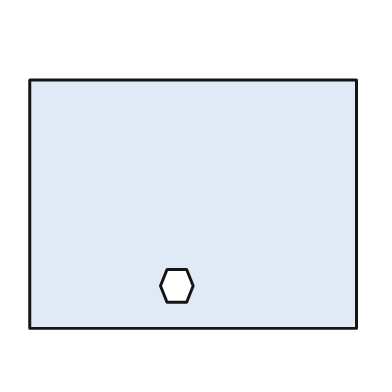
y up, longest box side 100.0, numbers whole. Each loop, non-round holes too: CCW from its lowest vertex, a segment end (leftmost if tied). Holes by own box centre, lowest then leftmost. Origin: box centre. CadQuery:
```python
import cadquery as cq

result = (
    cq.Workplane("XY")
    .moveTo(-50.0, -38.0)
    .lineTo(50.0, -38.0)
    .lineTo(50.0, 38.0)
    .lineTo(-50.0, 38.0)
    .close()
    .moveTo(-8.0, -30.0)
    .lineTo(-2.0, -30.0)
    .lineTo(0.0, -25.0)
    .lineTo(-2.0, -20.0)
    .lineTo(-8.0, -20.0)
    .lineTo(-10.0, -25.0)
    .close()
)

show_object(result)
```